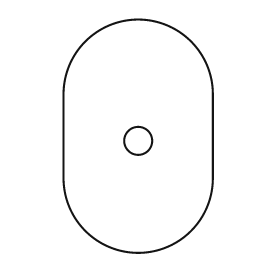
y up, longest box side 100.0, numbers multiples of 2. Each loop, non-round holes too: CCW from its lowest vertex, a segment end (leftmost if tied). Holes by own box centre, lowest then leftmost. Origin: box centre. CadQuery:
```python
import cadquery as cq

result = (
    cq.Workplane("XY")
    .moveTo(-32.0, -18.0)
    .threePointArc((0.0, -50.0), (32.0, -18.0))
    .lineTo(32.0, 18.0)
    .threePointArc((0.0, 50.0), (-32.0, 18.0))
    .close()
    .moveTo(0.0, -2.0)
    .circle(6.0)
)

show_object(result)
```